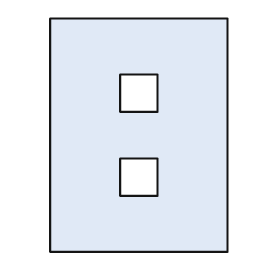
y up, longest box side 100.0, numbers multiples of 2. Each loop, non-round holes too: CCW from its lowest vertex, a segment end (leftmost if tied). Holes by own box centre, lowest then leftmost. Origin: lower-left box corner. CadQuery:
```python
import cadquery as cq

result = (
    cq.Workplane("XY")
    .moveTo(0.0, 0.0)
    .lineTo(76.0, 0.0)
    .lineTo(76.0, 100.0)
    .lineTo(0.0, 100.0)
    .close()
    .moveTo(30.0, 24.0)
    .lineTo(46.0, 24.0)
    .lineTo(46.0, 40.0)
    .lineTo(30.0, 40.0)
    .close()
    .moveTo(30.0, 60.0)
    .lineTo(46.0, 60.0)
    .lineTo(46.0, 76.0)
    .lineTo(30.0, 76.0)
    .close()
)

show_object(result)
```